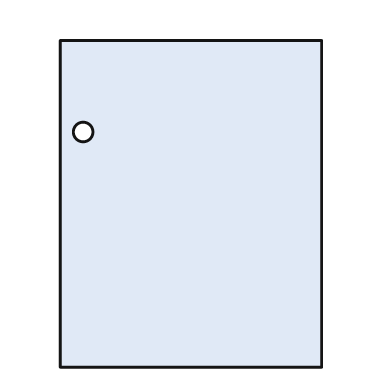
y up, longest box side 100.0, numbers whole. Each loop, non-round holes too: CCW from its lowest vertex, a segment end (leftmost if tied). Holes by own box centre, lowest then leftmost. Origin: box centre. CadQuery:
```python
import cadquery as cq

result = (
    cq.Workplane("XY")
    .moveTo(-40.0, -50.0)
    .lineTo(40.0, -50.0)
    .lineTo(40.0, 50.0)
    .lineTo(-40.0, 50.0)
    .close()
    .moveTo(-33.0, 22.0)
    .circle(3.0)
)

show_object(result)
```